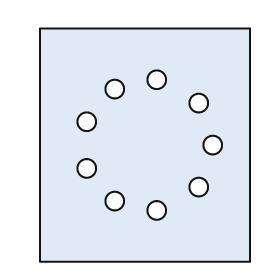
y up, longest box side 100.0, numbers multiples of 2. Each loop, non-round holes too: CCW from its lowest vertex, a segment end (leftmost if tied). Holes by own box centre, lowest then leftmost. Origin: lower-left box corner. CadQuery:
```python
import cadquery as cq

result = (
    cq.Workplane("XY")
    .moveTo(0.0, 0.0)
    .lineTo(90.0, 0.0)
    .lineTo(90.0, 100.0)
    .lineTo(0.0, 100.0)
    .close()
    .moveTo(50.0, 22.0)
    .circle(4.0)
    .moveTo(32.0, 26.0)
    .circle(4.0)
    .moveTo(68.0, 32.0)
    .circle(4.0)
    .moveTo(20.0, 40.0)
    .circle(4.0)
    .moveTo(74.0, 50.0)
    .circle(4.0)
    .moveTo(20.0, 60.0)
    .circle(4.0)
    .moveTo(68.0, 68.0)
    .circle(4.0)
    .moveTo(32.0, 74.0)
    .circle(4.0)
    .moveTo(50.0, 78.0)
    .circle(4.0)
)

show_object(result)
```